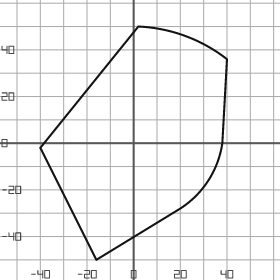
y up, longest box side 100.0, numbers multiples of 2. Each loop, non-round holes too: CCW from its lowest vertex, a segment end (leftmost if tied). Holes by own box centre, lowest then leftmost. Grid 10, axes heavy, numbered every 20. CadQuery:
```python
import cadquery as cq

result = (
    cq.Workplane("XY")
    .moveTo(-16.0, -50.0)
    .lineTo(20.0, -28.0)
    .threePointArc((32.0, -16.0), (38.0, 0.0))
    .lineTo(40.0, 36.0)
    .threePointArc((22.0, 46.0), (2.0, 50.0))
    .lineTo(-40.0, -2.0)
    .close()
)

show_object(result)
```